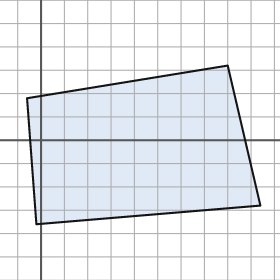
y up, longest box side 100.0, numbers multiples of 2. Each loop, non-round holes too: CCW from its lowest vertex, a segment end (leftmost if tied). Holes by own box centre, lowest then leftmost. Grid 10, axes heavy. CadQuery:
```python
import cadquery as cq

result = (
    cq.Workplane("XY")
    .moveTo(-2.0, -36.0)
    .lineTo(94.0, -28.0)
    .lineTo(80.0, 32.0)
    .lineTo(-6.0, 18.0)
    .close()
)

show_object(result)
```